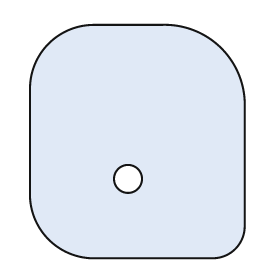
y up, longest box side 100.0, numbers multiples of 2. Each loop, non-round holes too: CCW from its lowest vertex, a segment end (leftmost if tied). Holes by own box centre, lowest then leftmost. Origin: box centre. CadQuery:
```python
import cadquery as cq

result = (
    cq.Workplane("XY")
    .moveTo(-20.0, -50.0)
    .lineTo(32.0, -50.0)
    .threePointArc((42.0, -46.0), (46.0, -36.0))
    .lineTo(46.0, 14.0)
    .threePointArc((36.0, 40.0), (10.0, 50.0))
    .lineTo(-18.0, 50.0)
    .threePointArc((-38.0, 42.0), (-46.0, 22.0))
    .lineTo(-46.0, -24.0)
    .threePointArc((-38.0, -42.0), (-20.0, -50.0))
    .close()
    .moveTo(-4.0, -16.0)
    .circle(6.0)
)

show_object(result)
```